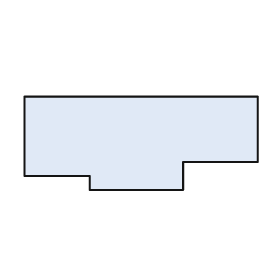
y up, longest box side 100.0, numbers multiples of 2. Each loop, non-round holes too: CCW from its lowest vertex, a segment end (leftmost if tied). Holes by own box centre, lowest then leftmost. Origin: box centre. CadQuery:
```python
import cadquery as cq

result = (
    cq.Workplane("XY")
    .moveTo(-22.0, -20.0)
    .lineTo(18.0, -20.0)
    .lineTo(18.0, -8.0)
    .lineTo(50.0, -8.0)
    .lineTo(50.0, 20.0)
    .lineTo(-50.0, 20.0)
    .lineTo(-50.0, -14.0)
    .lineTo(-22.0, -14.0)
    .close()
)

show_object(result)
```